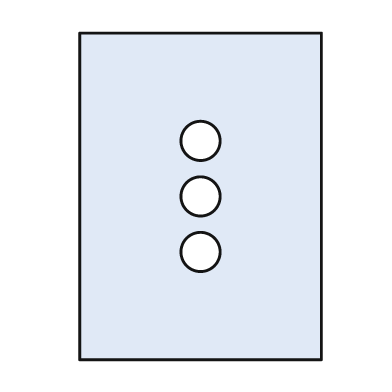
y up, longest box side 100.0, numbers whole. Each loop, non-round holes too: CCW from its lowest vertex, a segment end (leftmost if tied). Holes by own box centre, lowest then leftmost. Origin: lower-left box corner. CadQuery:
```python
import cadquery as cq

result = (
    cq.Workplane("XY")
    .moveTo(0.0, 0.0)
    .lineTo(74.0, 0.0)
    .lineTo(74.0, 100.0)
    .lineTo(0.0, 100.0)
    .close()
    .moveTo(37.0, 33.0)
    .circle(6.0)
    .moveTo(37.0, 50.0)
    .circle(6.0)
    .moveTo(37.0, 67.0)
    .circle(6.0)
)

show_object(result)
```